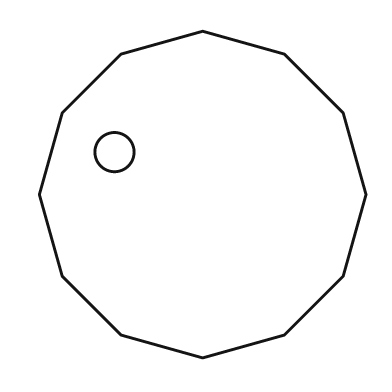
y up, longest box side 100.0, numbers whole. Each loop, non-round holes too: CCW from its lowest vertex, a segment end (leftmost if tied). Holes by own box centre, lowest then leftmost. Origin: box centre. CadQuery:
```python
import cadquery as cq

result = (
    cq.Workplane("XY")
    .moveTo(0.0, -50.0)
    .lineTo(25.0, -43.0)
    .lineTo(43.0, -25.0)
    .lineTo(50.0, 0.0)
    .lineTo(43.0, 25.0)
    .lineTo(25.0, 43.0)
    .lineTo(0.0, 50.0)
    .lineTo(-25.0, 43.0)
    .lineTo(-43.0, 25.0)
    .lineTo(-50.0, 0.0)
    .lineTo(-43.0, -25.0)
    .lineTo(-25.0, -43.0)
    .close()
    .moveTo(-27.0, 13.0)
    .circle(6.0)
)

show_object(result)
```